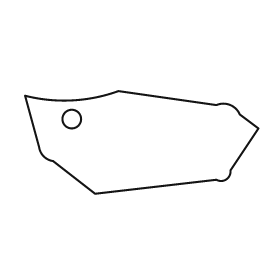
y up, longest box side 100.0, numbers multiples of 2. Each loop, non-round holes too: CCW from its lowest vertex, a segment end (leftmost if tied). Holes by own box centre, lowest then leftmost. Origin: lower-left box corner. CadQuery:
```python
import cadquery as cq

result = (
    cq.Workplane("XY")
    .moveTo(30.0, 0.0)
    .lineTo(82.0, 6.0)
    .threePointArc((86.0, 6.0), (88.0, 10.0))
    .lineTo(100.0, 28.0)
    .lineTo(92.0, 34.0)
    .threePointArc((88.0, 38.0), (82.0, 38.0))
    .lineTo(40.0, 44.0)
    .threePointArc((20.0, 40.0), (0.0, 42.0))
    .lineTo(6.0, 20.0)
    .threePointArc((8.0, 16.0), (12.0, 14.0))
    .close()
    .moveTo(20.0, 32.0)
    .circle(4.0)
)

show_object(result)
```